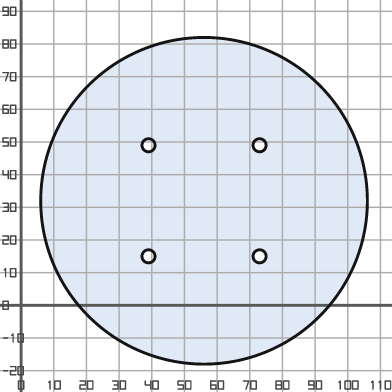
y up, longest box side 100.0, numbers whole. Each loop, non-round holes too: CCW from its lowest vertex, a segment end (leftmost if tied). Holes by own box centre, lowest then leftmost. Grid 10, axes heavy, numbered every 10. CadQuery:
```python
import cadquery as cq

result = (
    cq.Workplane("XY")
    .moveTo(56.0, 32.0)
    .circle(50.0)
    .moveTo(39.0, 15.0)
    .circle(2.0)
    .moveTo(73.0, 15.0)
    .circle(2.0)
    .moveTo(39.0, 49.0)
    .circle(2.0)
    .moveTo(73.0, 49.0)
    .circle(2.0)
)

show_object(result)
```